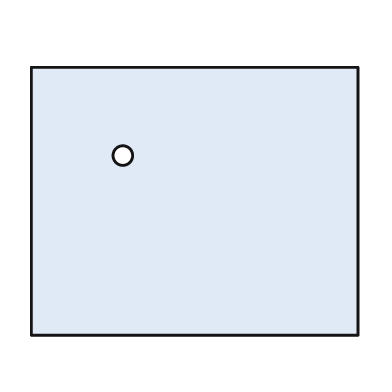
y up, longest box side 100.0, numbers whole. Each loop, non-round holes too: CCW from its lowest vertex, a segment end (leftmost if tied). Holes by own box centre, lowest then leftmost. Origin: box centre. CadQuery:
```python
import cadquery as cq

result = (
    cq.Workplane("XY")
    .moveTo(-50.0, -41.0)
    .lineTo(50.0, -41.0)
    .lineTo(50.0, 41.0)
    .lineTo(-50.0, 41.0)
    .close()
    .moveTo(-22.0, 14.0)
    .circle(3.0)
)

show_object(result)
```